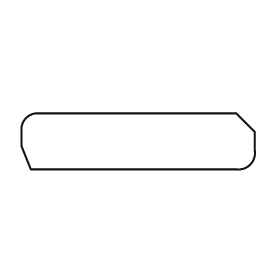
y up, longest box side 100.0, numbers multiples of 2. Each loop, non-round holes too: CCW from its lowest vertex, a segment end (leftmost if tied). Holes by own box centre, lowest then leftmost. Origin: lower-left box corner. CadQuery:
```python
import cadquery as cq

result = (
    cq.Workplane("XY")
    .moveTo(4.0, 0.0)
    .lineTo(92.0, 0.0)
    .threePointArc((98.0, 2.0), (100.0, 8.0))
    .lineTo(100.0, 16.0)
    .lineTo(92.0, 24.0)
    .lineTo(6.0, 24.0)
    .threePointArc((2.0, 22.0), (0.0, 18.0))
    .lineTo(0.0, 10.0)
    .close()
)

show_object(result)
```